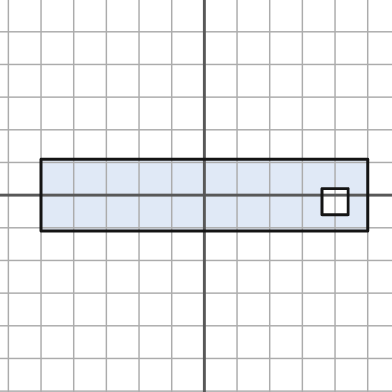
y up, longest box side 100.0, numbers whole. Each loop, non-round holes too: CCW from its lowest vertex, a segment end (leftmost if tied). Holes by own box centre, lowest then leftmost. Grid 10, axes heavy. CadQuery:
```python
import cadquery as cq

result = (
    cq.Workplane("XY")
    .moveTo(-50.0, -11.0)
    .lineTo(50.0, -11.0)
    .lineTo(50.0, 11.0)
    .lineTo(-50.0, 11.0)
    .close()
    .moveTo(36.0, -6.0)
    .lineTo(44.0, -6.0)
    .lineTo(44.0, 2.0)
    .lineTo(36.0, 2.0)
    .close()
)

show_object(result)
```